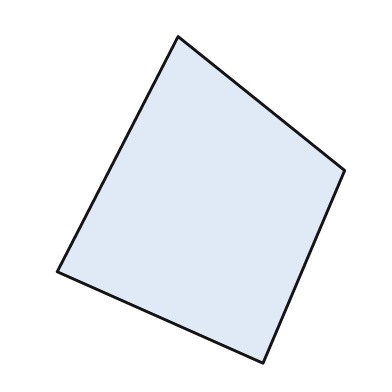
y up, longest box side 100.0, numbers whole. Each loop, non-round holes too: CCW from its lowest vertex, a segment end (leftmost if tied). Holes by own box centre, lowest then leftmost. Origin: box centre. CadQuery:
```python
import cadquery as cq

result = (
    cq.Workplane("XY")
    .moveTo(19.0, -50.0)
    .lineTo(44.0, 9.0)
    .lineTo(-7.0, 50.0)
    .lineTo(-44.0, -22.0)
    .close()
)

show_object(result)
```